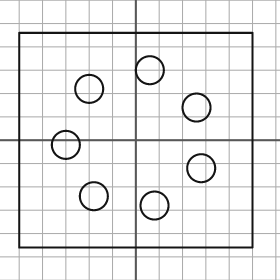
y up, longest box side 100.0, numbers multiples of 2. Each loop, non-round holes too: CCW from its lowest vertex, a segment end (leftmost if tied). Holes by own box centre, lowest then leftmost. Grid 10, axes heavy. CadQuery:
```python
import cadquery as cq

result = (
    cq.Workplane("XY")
    .moveTo(-50.0, -46.0)
    .lineTo(50.0, -46.0)
    .lineTo(50.0, 46.0)
    .lineTo(-50.0, 46.0)
    .close()
    .moveTo(8.0, -28.0)
    .circle(6.0)
    .moveTo(-18.0, -24.0)
    .circle(6.0)
    .moveTo(28.0, -12.0)
    .circle(6.0)
    .moveTo(-30.0, -2.0)
    .circle(6.0)
    .moveTo(26.0, 14.0)
    .circle(6.0)
    .moveTo(-20.0, 22.0)
    .circle(6.0)
    .moveTo(6.0, 30.0)
    .circle(6.0)
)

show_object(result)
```